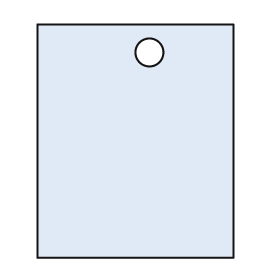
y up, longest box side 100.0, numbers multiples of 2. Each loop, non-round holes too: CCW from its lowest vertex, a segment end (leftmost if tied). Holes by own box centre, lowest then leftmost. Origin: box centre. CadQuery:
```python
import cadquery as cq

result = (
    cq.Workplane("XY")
    .moveTo(-42.0, -50.0)
    .lineTo(42.0, -50.0)
    .lineTo(42.0, 50.0)
    .lineTo(-42.0, 50.0)
    .close()
    .moveTo(6.0, 38.0)
    .circle(6.0)
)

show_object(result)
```